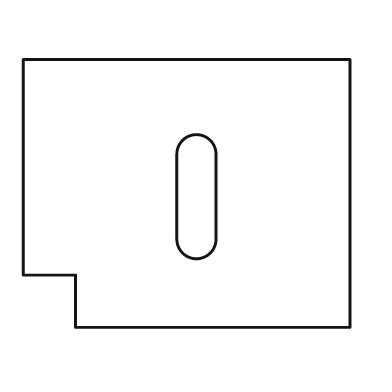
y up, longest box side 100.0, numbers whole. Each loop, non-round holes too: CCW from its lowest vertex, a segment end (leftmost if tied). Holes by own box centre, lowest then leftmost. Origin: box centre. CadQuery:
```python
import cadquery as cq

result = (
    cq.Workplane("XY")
    .moveTo(-34.0, -41.0)
    .lineTo(50.0, -41.0)
    .lineTo(50.0, 41.0)
    .lineTo(-50.0, 41.0)
    .lineTo(-50.0, -25.0)
    .lineTo(-34.0, -25.0)
    .close()
    .moveTo(-3.0, -14.0)
    .threePointArc((3.0, -20.0), (9.0, -14.0))
    .lineTo(9.0, 12.0)
    .threePointArc((3.0, 18.0), (-3.0, 12.0))
    .close()
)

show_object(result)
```